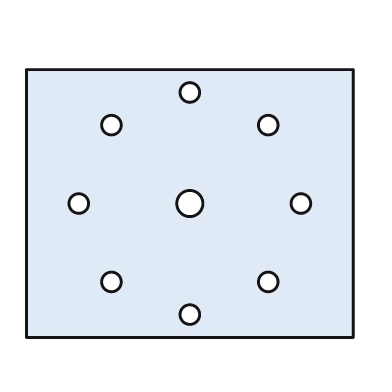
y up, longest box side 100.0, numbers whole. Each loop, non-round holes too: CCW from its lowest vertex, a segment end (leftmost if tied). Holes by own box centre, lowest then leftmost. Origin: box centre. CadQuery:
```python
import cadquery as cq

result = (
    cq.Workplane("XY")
    .moveTo(-50.0, -41.0)
    .lineTo(50.0, -41.0)
    .lineTo(50.0, 41.0)
    .lineTo(-50.0, 41.0)
    .close()
    .moveTo(0.0, -34.0)
    .circle(3.0)
    .moveTo(-24.0, -24.0)
    .circle(3.0)
    .moveTo(24.0, -24.0)
    .circle(3.0)
    .moveTo(-34.0, 0.0)
    .circle(3.0)
    .moveTo(0.0, 0.0)
    .circle(4.0)
    .moveTo(34.0, 0.0)
    .circle(3.0)
    .moveTo(-24.0, 24.0)
    .circle(3.0)
    .moveTo(24.0, 24.0)
    .circle(3.0)
    .moveTo(0.0, 34.0)
    .circle(3.0)
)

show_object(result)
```